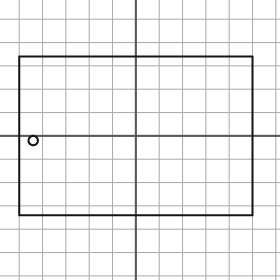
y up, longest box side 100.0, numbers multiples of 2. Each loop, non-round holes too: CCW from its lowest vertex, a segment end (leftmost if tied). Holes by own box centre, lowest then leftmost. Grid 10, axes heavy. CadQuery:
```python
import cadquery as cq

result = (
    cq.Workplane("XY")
    .moveTo(-50.0, -34.0)
    .lineTo(50.0, -34.0)
    .lineTo(50.0, 34.0)
    .lineTo(-50.0, 34.0)
    .close()
    .moveTo(-44.0, -2.0)
    .circle(2.0)
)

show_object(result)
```